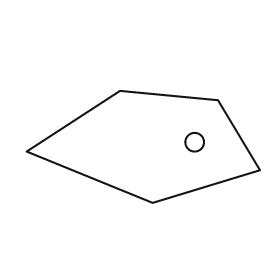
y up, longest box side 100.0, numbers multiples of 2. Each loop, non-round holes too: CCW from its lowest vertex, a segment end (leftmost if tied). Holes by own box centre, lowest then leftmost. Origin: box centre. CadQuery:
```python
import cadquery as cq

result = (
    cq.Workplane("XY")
    .moveTo(4.0, -24.0)
    .lineTo(50.0, -10.0)
    .lineTo(32.0, 20.0)
    .lineTo(-10.0, 24.0)
    .lineTo(-50.0, -2.0)
    .close()
    .moveTo(22.0, 2.0)
    .circle(4.0)
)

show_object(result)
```